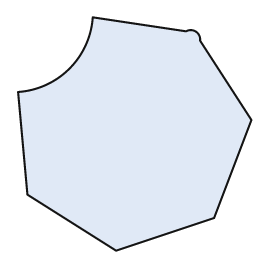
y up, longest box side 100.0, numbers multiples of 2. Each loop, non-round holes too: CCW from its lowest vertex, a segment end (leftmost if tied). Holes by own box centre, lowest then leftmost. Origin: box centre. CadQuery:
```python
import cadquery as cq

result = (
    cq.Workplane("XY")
    .moveTo(-8.0, -50.0)
    .lineTo(34.0, -36.0)
    .lineTo(50.0, 6.0)
    .lineTo(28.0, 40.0)
    .threePointArc((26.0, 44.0), (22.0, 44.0))
    .lineTo(-18.0, 50.0)
    .threePointArc((-28.0, 28.0), (-50.0, 18.0))
    .lineTo(-46.0, -26.0)
    .close()
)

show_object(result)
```